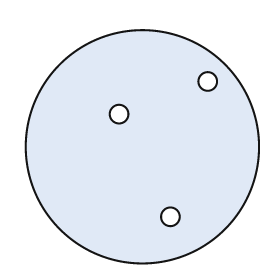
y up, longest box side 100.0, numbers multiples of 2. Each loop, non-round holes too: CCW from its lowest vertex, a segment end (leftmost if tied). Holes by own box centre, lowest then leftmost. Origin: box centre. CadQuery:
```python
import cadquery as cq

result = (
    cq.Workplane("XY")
    .moveTo(0.0, 0.0)
    .circle(50.0)
    .moveTo(12.0, -30.0)
    .circle(4.0)
    .moveTo(-10.0, 14.0)
    .circle(4.0)
    .moveTo(28.0, 28.0)
    .circle(4.0)
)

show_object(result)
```